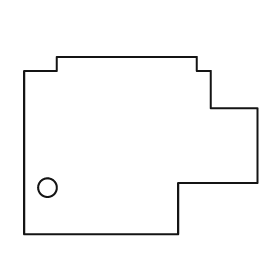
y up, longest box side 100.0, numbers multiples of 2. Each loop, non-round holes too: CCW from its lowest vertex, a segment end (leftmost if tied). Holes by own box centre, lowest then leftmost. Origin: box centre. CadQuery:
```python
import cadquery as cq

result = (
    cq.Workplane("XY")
    .moveTo(-50.0, -38.0)
    .lineTo(16.0, -38.0)
    .lineTo(16.0, -16.0)
    .lineTo(50.0, -16.0)
    .lineTo(50.0, 16.0)
    .lineTo(30.0, 16.0)
    .lineTo(30.0, 32.0)
    .lineTo(24.0, 32.0)
    .lineTo(24.0, 38.0)
    .lineTo(-36.0, 38.0)
    .lineTo(-36.0, 32.0)
    .lineTo(-50.0, 32.0)
    .close()
    .moveTo(-40.0, -18.0)
    .circle(4.0)
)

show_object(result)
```